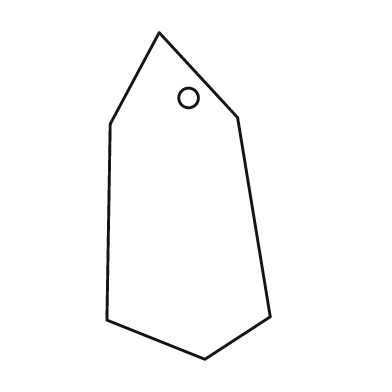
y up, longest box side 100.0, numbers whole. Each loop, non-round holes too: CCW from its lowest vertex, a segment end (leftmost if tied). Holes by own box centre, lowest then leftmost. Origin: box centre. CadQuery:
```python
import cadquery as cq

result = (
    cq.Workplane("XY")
    .moveTo(5.0, -50.0)
    .lineTo(25.0, -37.0)
    .lineTo(15.0, 24.0)
    .lineTo(-9.0, 50.0)
    .lineTo(-24.0, 22.0)
    .lineTo(-25.0, -38.0)
    .close()
    .moveTo(0.0, 30.0)
    .circle(3.0)
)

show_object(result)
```